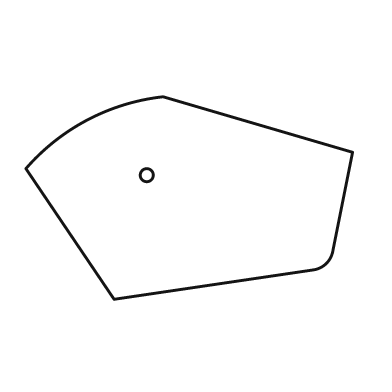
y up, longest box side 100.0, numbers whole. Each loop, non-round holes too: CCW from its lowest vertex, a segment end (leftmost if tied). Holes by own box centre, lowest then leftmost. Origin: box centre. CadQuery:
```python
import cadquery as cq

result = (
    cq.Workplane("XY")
    .moveTo(-23.0, -31.0)
    .lineTo(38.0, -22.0)
    .threePointArc((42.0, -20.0), (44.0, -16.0))
    .lineTo(50.0, 14.0)
    .lineTo(-8.0, 31.0)
    .threePointArc((-31.0, 24.0), (-50.0, 9.0))
    .close()
    .moveTo(-13.0, 7.0)
    .circle(2.0)
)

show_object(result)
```